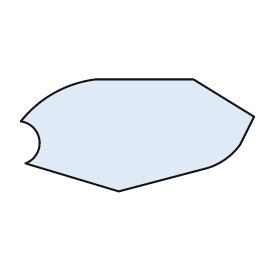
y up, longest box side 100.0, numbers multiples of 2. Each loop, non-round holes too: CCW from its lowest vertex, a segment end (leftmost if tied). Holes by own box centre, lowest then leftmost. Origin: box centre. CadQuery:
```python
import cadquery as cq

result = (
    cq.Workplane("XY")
    .moveTo(-8.0, -24.0)
    .lineTo(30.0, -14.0)
    .threePointArc((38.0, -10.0), (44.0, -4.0))
    .lineTo(50.0, 8.0)
    .lineTo(24.0, 24.0)
    .lineTo(-18.0, 24.0)
    .threePointArc((-36.0, 18.0), (-50.0, 6.0))
    .threePointArc((-42.0, -2.0), (-48.0, -12.0))
    .close()
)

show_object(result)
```